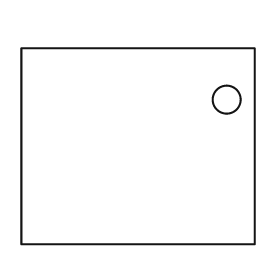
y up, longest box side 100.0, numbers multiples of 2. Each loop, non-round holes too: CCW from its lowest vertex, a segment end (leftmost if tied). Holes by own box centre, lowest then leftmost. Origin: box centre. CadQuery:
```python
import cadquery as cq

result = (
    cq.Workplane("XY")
    .moveTo(-50.0, -42.0)
    .lineTo(50.0, -42.0)
    .lineTo(50.0, 42.0)
    .lineTo(-50.0, 42.0)
    .close()
    .moveTo(38.0, 20.0)
    .circle(6.0)
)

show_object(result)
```